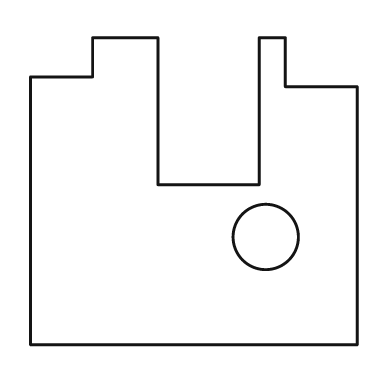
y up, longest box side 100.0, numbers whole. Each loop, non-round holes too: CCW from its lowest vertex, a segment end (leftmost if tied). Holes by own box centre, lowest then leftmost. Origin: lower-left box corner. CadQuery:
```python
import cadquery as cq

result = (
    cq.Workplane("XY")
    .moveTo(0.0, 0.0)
    .lineTo(100.0, 0.0)
    .lineTo(100.0, 79.0)
    .lineTo(78.0, 79.0)
    .lineTo(78.0, 94.0)
    .lineTo(70.0, 94.0)
    .lineTo(70.0, 49.0)
    .lineTo(39.0, 49.0)
    .lineTo(39.0, 94.0)
    .lineTo(19.0, 94.0)
    .lineTo(19.0, 82.0)
    .lineTo(0.0, 82.0)
    .close()
    .moveTo(72.0, 33.0)
    .circle(10.0)
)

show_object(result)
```